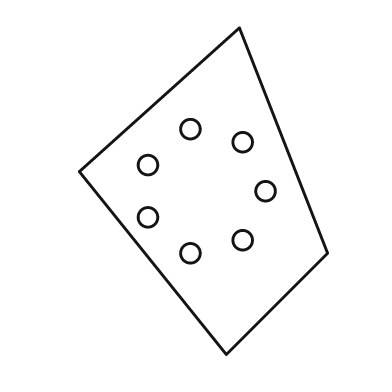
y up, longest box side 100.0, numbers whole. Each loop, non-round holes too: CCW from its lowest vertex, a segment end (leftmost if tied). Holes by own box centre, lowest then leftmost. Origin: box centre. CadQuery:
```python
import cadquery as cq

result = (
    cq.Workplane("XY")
    .moveTo(7.0, -50.0)
    .lineTo(38.0, -19.0)
    .lineTo(11.0, 50.0)
    .lineTo(-38.0, 6.0)
    .close()
    .moveTo(-4.0, -19.0)
    .circle(3.0)
    .moveTo(12.0, -15.0)
    .circle(3.0)
    .moveTo(-17.0, -8.0)
    .circle(3.0)
    .moveTo(19.0, 0.0)
    .circle(3.0)
    .moveTo(-17.0, 8.0)
    .circle(3.0)
    .moveTo(12.0, 15.0)
    .circle(3.0)
    .moveTo(-4.0, 19.0)
    .circle(3.0)
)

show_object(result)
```